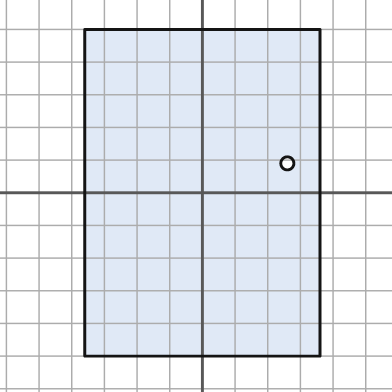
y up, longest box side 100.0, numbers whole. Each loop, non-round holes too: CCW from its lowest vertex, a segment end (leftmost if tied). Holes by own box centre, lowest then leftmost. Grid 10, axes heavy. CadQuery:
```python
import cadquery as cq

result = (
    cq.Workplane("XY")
    .moveTo(-36.0, -50.0)
    .lineTo(36.0, -50.0)
    .lineTo(36.0, 50.0)
    .lineTo(-36.0, 50.0)
    .close()
    .moveTo(26.0, 9.0)
    .circle(2.0)
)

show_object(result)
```